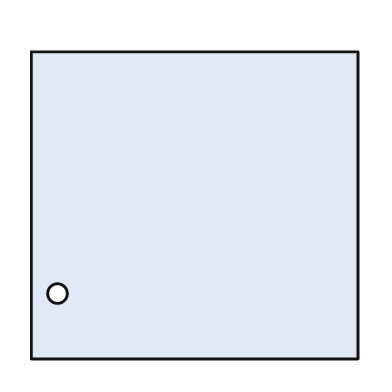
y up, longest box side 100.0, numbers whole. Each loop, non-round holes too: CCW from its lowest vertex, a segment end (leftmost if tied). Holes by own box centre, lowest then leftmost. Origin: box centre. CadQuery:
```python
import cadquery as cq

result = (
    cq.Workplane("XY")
    .moveTo(-50.0, -47.0)
    .lineTo(50.0, -47.0)
    .lineTo(50.0, 47.0)
    .lineTo(-50.0, 47.0)
    .close()
    .moveTo(-42.0, -27.0)
    .circle(3.0)
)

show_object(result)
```